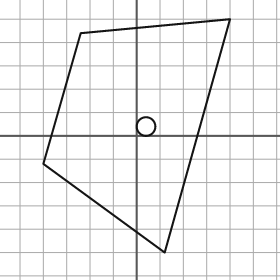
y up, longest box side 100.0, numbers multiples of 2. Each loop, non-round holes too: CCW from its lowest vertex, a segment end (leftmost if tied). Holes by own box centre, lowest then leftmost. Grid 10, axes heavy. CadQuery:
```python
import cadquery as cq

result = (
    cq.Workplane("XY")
    .moveTo(12.0, -50.0)
    .lineTo(40.0, 50.0)
    .lineTo(-24.0, 44.0)
    .lineTo(-40.0, -12.0)
    .close()
    .moveTo(4.0, 4.0)
    .circle(4.0)
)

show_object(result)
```